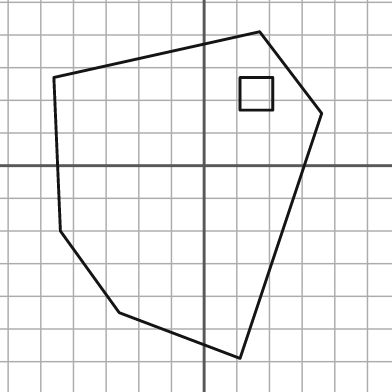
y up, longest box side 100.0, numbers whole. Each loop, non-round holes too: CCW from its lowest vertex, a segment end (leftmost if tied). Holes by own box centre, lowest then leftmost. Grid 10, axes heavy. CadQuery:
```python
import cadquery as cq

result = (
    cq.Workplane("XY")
    .moveTo(11.0, -59.0)
    .lineTo(36.0, 16.0)
    .lineTo(17.0, 41.0)
    .lineTo(-46.0, 27.0)
    .lineTo(-44.0, -20.0)
    .lineTo(-26.0, -45.0)
    .close()
    .moveTo(11.0, 17.0)
    .lineTo(21.0, 17.0)
    .lineTo(21.0, 27.0)
    .lineTo(11.0, 27.0)
    .close()
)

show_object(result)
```